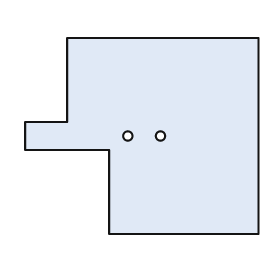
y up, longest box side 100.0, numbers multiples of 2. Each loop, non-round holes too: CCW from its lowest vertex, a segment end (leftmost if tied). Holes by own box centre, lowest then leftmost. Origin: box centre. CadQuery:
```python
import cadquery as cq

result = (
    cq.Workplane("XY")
    .moveTo(-14.0, -42.0)
    .lineTo(50.0, -42.0)
    .lineTo(50.0, 42.0)
    .lineTo(-32.0, 42.0)
    .lineTo(-32.0, 6.0)
    .lineTo(-50.0, 6.0)
    .lineTo(-50.0, -6.0)
    .lineTo(-14.0, -6.0)
    .close()
    .moveTo(-6.0, 0.0)
    .circle(2.0)
    .moveTo(8.0, 0.0)
    .circle(2.0)
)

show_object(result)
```